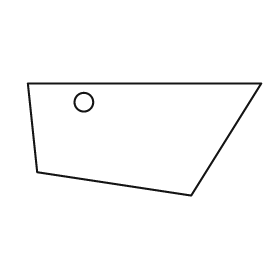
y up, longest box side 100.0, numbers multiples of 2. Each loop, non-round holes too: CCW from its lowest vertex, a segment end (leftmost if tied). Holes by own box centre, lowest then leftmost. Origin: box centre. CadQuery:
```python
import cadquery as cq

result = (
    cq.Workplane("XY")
    .moveTo(20.0, -24.0)
    .lineTo(50.0, 24.0)
    .lineTo(-50.0, 24.0)
    .lineTo(-46.0, -14.0)
    .close()
    .moveTo(-26.0, 16.0)
    .circle(4.0)
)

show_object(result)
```